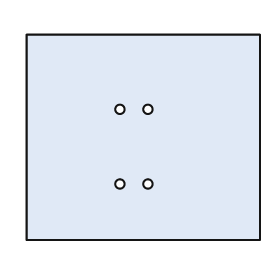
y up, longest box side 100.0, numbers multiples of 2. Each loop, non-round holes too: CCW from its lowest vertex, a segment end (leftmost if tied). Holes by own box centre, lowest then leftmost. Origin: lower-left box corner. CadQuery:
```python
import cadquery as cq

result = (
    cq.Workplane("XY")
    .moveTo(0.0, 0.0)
    .lineTo(100.0, 0.0)
    .lineTo(100.0, 88.0)
    .lineTo(0.0, 88.0)
    .close()
    .moveTo(40.0, 24.0)
    .circle(2.0)
    .moveTo(52.0, 24.0)
    .circle(2.0)
    .moveTo(40.0, 56.0)
    .circle(2.0)
    .moveTo(52.0, 56.0)
    .circle(2.0)
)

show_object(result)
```